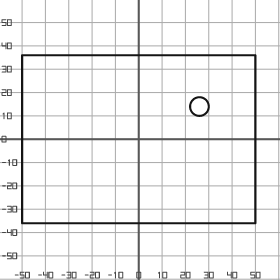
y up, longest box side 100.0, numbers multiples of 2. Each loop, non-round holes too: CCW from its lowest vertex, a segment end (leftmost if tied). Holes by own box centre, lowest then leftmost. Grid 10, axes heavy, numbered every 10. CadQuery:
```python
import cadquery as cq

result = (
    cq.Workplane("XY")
    .moveTo(-50.0, -36.0)
    .lineTo(50.0, -36.0)
    .lineTo(50.0, 36.0)
    .lineTo(-50.0, 36.0)
    .close()
    .moveTo(26.0, 14.0)
    .circle(4.0)
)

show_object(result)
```